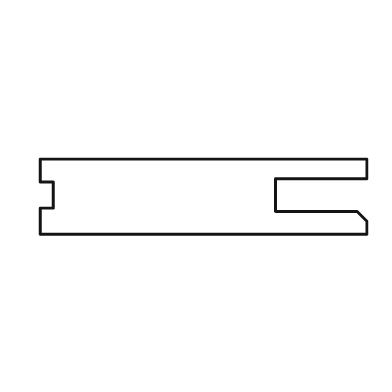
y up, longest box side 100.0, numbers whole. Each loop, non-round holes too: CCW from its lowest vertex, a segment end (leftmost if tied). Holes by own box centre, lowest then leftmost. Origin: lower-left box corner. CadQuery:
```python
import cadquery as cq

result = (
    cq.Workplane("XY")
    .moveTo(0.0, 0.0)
    .lineTo(100.0, 0.0)
    .lineTo(100.0, 4.0)
    .lineTo(97.0, 7.0)
    .lineTo(72.0, 7.0)
    .lineTo(72.0, 17.0)
    .lineTo(100.0, 17.0)
    .lineTo(100.0, 23.0)
    .lineTo(0.0, 23.0)
    .lineTo(0.0, 16.0)
    .lineTo(4.0, 16.0)
    .lineTo(4.0, 8.0)
    .lineTo(0.0, 8.0)
    .close()
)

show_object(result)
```